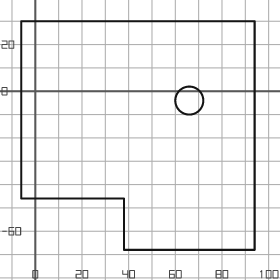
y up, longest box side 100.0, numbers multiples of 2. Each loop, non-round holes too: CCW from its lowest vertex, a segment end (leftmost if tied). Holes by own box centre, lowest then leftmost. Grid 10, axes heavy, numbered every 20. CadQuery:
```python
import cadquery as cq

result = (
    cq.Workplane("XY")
    .moveTo(38.0, -68.0)
    .lineTo(94.0, -68.0)
    .lineTo(94.0, 30.0)
    .lineTo(-6.0, 30.0)
    .lineTo(-6.0, -46.0)
    .lineTo(38.0, -46.0)
    .close()
    .moveTo(66.0, -4.0)
    .circle(6.0)
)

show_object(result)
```